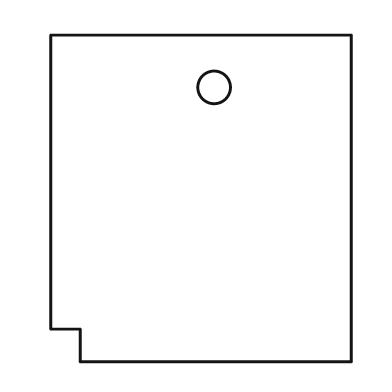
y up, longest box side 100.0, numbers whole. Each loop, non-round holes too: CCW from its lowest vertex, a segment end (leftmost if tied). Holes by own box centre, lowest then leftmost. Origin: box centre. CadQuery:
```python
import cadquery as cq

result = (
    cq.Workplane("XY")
    .moveTo(-37.0, -50.0)
    .lineTo(46.0, -50.0)
    .lineTo(46.0, 50.0)
    .lineTo(-46.0, 50.0)
    .lineTo(-46.0, -40.0)
    .lineTo(-37.0, -40.0)
    .close()
    .moveTo(4.0, 34.0)
    .circle(5.0)
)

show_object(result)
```